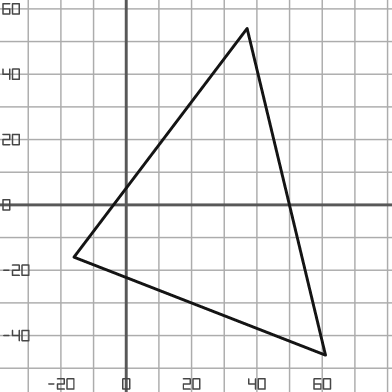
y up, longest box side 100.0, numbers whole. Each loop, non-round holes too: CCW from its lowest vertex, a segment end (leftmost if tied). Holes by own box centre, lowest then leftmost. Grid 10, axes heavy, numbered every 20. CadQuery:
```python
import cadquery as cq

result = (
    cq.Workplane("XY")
    .moveTo(61.0, -46.0)
    .lineTo(37.0, 54.0)
    .lineTo(-16.0, -16.0)
    .close()
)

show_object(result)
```